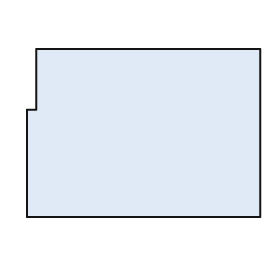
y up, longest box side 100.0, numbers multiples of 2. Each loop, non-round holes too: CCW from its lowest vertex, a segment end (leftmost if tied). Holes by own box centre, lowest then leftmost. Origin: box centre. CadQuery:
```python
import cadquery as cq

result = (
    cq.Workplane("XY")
    .moveTo(-50.0, -36.0)
    .lineTo(50.0, -36.0)
    .lineTo(50.0, 36.0)
    .lineTo(-46.0, 36.0)
    .lineTo(-46.0, 10.0)
    .lineTo(-50.0, 10.0)
    .close()
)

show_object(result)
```